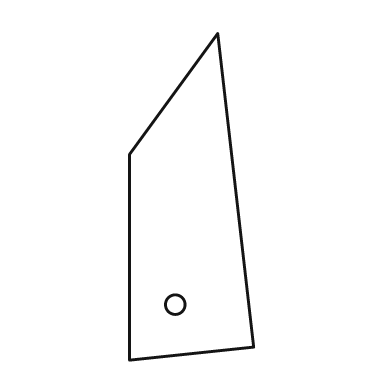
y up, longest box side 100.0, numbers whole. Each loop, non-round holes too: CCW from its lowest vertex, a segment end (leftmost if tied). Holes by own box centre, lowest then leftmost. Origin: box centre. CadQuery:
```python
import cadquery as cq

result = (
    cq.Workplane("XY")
    .moveTo(-19.0, -50.0)
    .lineTo(19.0, -46.0)
    .lineTo(8.0, 50.0)
    .lineTo(-19.0, 13.0)
    .close()
    .moveTo(-5.0, -33.0)
    .circle(3.0)
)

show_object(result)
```